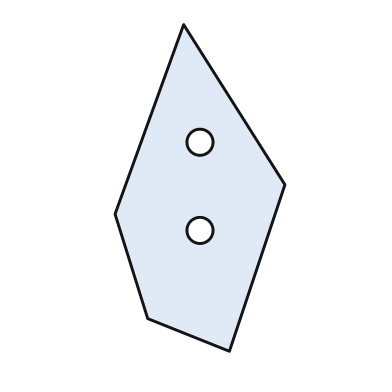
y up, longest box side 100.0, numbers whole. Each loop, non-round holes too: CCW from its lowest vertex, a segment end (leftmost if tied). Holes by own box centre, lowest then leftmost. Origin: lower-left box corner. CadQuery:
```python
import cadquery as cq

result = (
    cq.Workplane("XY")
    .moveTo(35.0, 0.0)
    .lineTo(52.0, 51.0)
    .lineTo(21.0, 100.0)
    .lineTo(0.0, 42.0)
    .lineTo(10.0, 10.0)
    .close()
    .moveTo(26.0, 37.0)
    .circle(4.0)
    .moveTo(26.0, 64.0)
    .circle(4.0)
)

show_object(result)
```